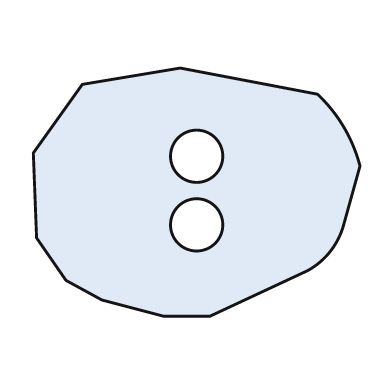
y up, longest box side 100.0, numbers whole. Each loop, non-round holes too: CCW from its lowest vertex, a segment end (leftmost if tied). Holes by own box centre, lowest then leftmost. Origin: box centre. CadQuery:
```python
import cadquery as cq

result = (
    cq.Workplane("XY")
    .moveTo(-10.0, -38.0)
    .lineTo(4.0, -38.0)
    .lineTo(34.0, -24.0)
    .threePointArc((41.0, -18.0), (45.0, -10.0))
    .lineTo(50.0, 8.0)
    .threePointArc((45.0, 20.0), (37.0, 30.0))
    .lineTo(-5.0, 38.0)
    .lineTo(-35.0, 33.0)
    .lineTo(-50.0, 12.0)
    .lineTo(-49.0, -14.0)
    .lineTo(-40.0, -27.0)
    .lineTo(-29.0, -33.0)
    .close()
    .moveTo(0.0, -10.0)
    .circle(8.0)
    .moveTo(0.0, 11.0)
    .circle(8.0)
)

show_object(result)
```